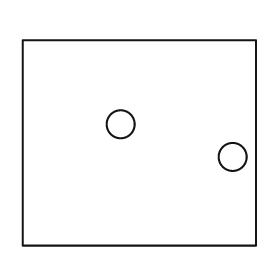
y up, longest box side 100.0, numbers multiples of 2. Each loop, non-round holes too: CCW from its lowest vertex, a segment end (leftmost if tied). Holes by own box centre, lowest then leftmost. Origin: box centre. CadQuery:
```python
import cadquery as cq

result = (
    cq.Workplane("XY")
    .moveTo(-50.0, -44.0)
    .lineTo(50.0, -44.0)
    .lineTo(50.0, 44.0)
    .lineTo(-50.0, 44.0)
    .close()
    .moveTo(40.0, -6.0)
    .circle(6.0)
    .moveTo(-8.0, 8.0)
    .circle(6.0)
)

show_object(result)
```